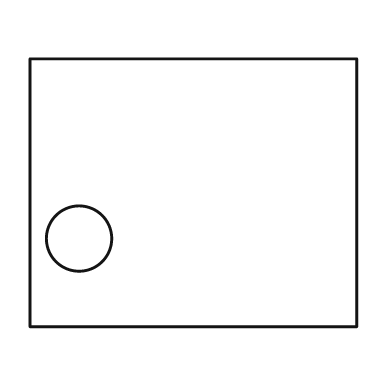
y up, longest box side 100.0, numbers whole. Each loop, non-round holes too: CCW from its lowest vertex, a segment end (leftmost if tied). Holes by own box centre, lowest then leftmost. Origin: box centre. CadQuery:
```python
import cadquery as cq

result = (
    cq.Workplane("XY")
    .moveTo(-50.0, -41.0)
    .lineTo(50.0, -41.0)
    .lineTo(50.0, 41.0)
    .lineTo(-50.0, 41.0)
    .close()
    .moveTo(-35.0, -14.0)
    .circle(10.0)
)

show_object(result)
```